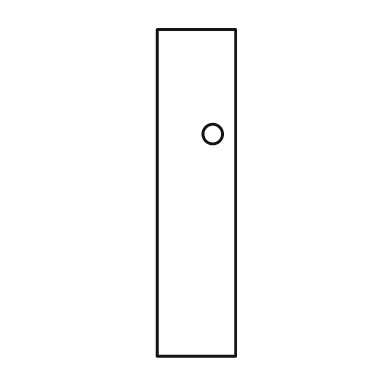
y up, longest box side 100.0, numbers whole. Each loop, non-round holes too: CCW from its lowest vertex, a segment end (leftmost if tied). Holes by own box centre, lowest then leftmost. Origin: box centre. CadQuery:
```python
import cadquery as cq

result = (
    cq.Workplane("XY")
    .moveTo(-12.0, -50.0)
    .lineTo(12.0, -50.0)
    .lineTo(12.0, 50.0)
    .lineTo(-12.0, 50.0)
    .close()
    .moveTo(5.0, 18.0)
    .circle(3.0)
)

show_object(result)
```